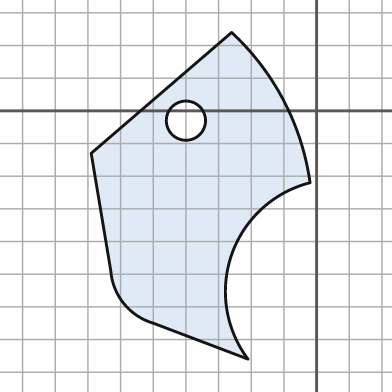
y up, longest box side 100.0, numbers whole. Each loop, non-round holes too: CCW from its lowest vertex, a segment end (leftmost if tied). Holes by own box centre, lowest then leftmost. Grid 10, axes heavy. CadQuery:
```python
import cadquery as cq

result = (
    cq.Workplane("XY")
    .moveTo(-21.0, -76.0)
    .threePointArc((-26.0, -44.0), (-2.0, -22.0))
    .threePointArc((-10.0, 3.0), (-26.0, 24.0))
    .lineTo(-69.0, -13.0)
    .lineTo(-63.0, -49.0)
    .threePointArc((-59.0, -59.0), (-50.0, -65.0))
    .close()
    .moveTo(-40.0, -3.0)
    .circle(6.0)
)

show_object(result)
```